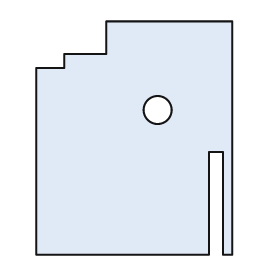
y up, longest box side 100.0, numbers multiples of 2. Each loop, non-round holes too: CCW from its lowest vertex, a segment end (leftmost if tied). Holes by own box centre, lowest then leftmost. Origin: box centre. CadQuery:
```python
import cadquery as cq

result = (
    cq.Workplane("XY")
    .moveTo(-42.0, -50.0)
    .lineTo(32.0, -50.0)
    .lineTo(32.0, -6.0)
    .lineTo(38.0, -6.0)
    .lineTo(38.0, -50.0)
    .lineTo(42.0, -50.0)
    .lineTo(42.0, 50.0)
    .lineTo(-12.0, 50.0)
    .lineTo(-12.0, 36.0)
    .lineTo(-30.0, 36.0)
    .lineTo(-30.0, 30.0)
    .lineTo(-42.0, 30.0)
    .close()
    .moveTo(10.0, 12.0)
    .circle(6.0)
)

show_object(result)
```